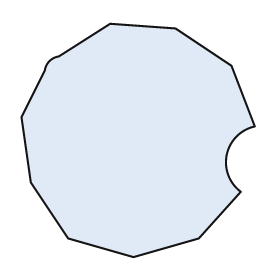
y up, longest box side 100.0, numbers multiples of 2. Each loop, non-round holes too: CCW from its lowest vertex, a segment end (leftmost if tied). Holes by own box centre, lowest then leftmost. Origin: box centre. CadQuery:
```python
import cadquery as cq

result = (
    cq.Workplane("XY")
    .moveTo(-2.0, -50.0)
    .lineTo(26.0, -42.0)
    .lineTo(44.0, -22.0)
    .threePointArc((38.0, -6.0), (50.0, 6.0))
    .lineTo(40.0, 32.0)
    .lineTo(16.0, 48.0)
    .lineTo(-12.0, 50.0)
    .lineTo(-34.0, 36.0)
    .threePointArc((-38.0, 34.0), (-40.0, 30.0))
    .lineTo(-50.0, 10.0)
    .lineTo(-46.0, -18.0)
    .lineTo(-30.0, -42.0)
    .close()
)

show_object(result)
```